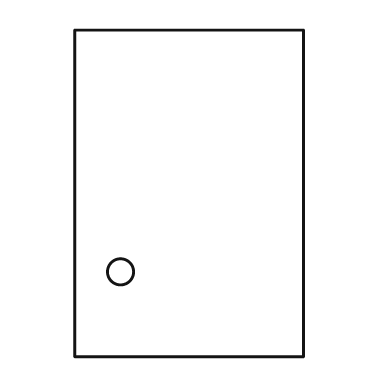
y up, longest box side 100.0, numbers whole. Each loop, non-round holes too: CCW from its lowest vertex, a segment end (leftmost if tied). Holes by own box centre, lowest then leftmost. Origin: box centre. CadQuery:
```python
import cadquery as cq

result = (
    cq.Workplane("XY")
    .moveTo(-35.0, -50.0)
    .lineTo(35.0, -50.0)
    .lineTo(35.0, 50.0)
    .lineTo(-35.0, 50.0)
    .close()
    .moveTo(-21.0, -24.0)
    .circle(4.0)
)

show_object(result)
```